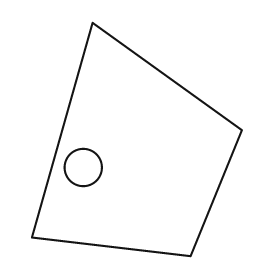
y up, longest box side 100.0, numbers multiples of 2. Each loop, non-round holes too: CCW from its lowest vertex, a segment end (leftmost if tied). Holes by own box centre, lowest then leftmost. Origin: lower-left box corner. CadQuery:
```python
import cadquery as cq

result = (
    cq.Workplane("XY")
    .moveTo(68.0, 0.0)
    .lineTo(90.0, 54.0)
    .lineTo(26.0, 100.0)
    .lineTo(0.0, 8.0)
    .close()
    .moveTo(22.0, 38.0)
    .circle(8.0)
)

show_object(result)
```